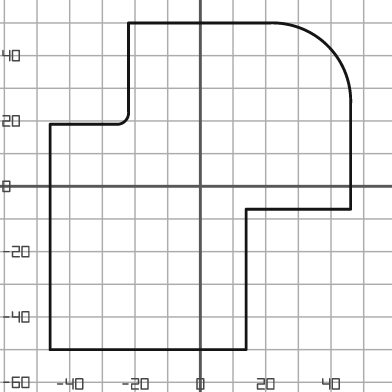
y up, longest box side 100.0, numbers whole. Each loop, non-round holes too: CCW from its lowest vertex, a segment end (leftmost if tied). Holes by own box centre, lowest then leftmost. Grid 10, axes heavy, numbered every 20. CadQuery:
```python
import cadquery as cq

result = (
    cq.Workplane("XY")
    .moveTo(-46.0, -50.0)
    .lineTo(14.0, -50.0)
    .lineTo(14.0, -7.0)
    .lineTo(46.0, -7.0)
    .lineTo(46.0, 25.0)
    .threePointArc((39.0, 43.0), (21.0, 50.0))
    .lineTo(-22.0, 50.0)
    .lineTo(-22.0, 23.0)
    .threePointArc((-23.0, 20.0), (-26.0, 19.0))
    .lineTo(-46.0, 19.0)
    .close()
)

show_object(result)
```